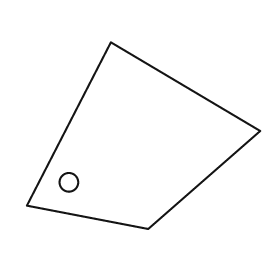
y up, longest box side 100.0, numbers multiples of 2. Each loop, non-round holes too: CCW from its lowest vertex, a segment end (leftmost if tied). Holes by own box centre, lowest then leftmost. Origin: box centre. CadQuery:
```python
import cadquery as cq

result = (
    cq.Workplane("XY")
    .moveTo(2.0, -40.0)
    .lineTo(50.0, 2.0)
    .lineTo(-14.0, 40.0)
    .lineTo(-50.0, -30.0)
    .close()
    .moveTo(-32.0, -20.0)
    .circle(4.0)
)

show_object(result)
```